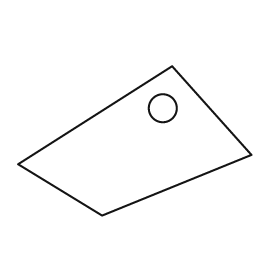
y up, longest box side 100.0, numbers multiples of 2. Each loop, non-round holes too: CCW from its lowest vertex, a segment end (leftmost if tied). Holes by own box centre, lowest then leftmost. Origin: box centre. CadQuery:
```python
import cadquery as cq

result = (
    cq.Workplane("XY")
    .moveTo(-14.0, -32.0)
    .lineTo(50.0, -6.0)
    .lineTo(16.0, 32.0)
    .lineTo(-50.0, -10.0)
    .close()
    .moveTo(12.0, 14.0)
    .circle(6.0)
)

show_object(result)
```